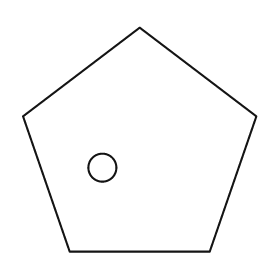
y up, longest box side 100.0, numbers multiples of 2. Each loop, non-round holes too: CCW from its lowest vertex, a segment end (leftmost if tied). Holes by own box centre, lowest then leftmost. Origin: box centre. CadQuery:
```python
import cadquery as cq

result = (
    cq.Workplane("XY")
    .moveTo(-30.0, -48.0)
    .lineTo(30.0, -48.0)
    .lineTo(50.0, 10.0)
    .lineTo(0.0, 48.0)
    .lineTo(-50.0, 10.0)
    .close()
    .moveTo(-16.0, -12.0)
    .circle(6.0)
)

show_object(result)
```